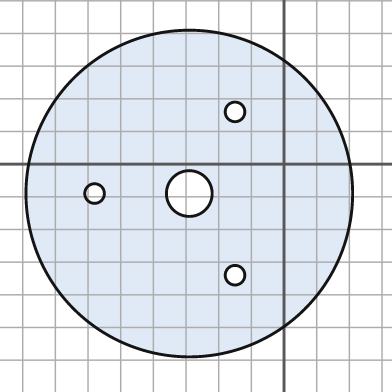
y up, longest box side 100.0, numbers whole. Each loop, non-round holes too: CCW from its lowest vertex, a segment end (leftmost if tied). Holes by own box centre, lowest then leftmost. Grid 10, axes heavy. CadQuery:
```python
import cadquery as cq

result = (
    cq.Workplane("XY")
    .moveTo(-29.0, -9.0)
    .circle(50.0)
    .moveTo(-15.0, -34.0)
    .circle(3.0)
    .moveTo(-58.0, -9.0)
    .circle(3.0)
    .moveTo(-29.0, -9.0)
    .circle(7.0)
    .moveTo(-15.0, 16.0)
    .circle(3.0)
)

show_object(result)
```